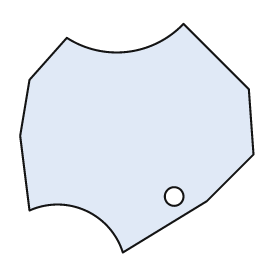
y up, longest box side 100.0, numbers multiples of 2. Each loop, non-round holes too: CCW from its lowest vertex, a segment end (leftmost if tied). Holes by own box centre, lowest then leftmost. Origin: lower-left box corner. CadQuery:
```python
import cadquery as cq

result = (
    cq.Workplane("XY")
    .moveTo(44.0, 0.0)
    .lineTo(80.0, 22.0)
    .lineTo(100.0, 42.0)
    .lineTo(98.0, 70.0)
    .lineTo(70.0, 98.0)
    .threePointArc((46.0, 86.0), (20.0, 92.0))
    .lineTo(4.0, 74.0)
    .lineTo(0.0, 50.0)
    .lineTo(4.0, 18.0)
    .threePointArc((28.0, 18.0), (44.0, 0.0))
    .close()
    .moveTo(66.0, 24.0)
    .circle(4.0)
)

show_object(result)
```